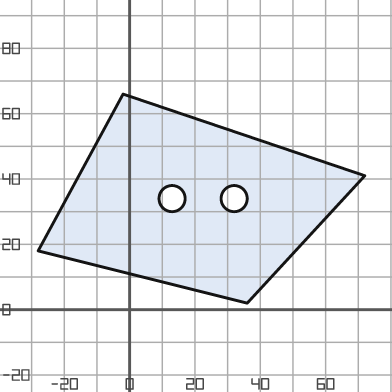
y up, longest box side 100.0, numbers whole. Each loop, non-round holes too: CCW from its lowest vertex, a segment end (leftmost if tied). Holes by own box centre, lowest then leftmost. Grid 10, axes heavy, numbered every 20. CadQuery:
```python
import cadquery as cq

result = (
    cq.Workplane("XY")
    .moveTo(36.0, 2.0)
    .lineTo(72.0, 41.0)
    .lineTo(-2.0, 66.0)
    .lineTo(-28.0, 18.0)
    .close()
    .moveTo(13.0, 34.0)
    .circle(4.0)
    .moveTo(32.0, 34.0)
    .circle(4.0)
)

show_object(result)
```